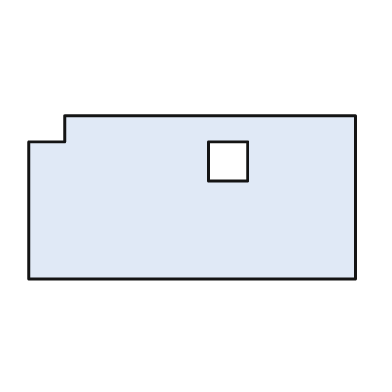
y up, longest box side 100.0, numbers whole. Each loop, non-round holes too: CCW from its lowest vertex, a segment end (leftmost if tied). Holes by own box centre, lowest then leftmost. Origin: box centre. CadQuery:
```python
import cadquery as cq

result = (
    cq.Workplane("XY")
    .moveTo(-50.0, -25.0)
    .lineTo(50.0, -25.0)
    .lineTo(50.0, 25.0)
    .lineTo(-39.0, 25.0)
    .lineTo(-39.0, 17.0)
    .lineTo(-50.0, 17.0)
    .close()
    .moveTo(5.0, 5.0)
    .lineTo(17.0, 5.0)
    .lineTo(17.0, 17.0)
    .lineTo(5.0, 17.0)
    .close()
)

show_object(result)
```